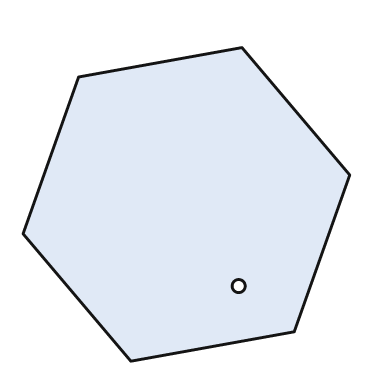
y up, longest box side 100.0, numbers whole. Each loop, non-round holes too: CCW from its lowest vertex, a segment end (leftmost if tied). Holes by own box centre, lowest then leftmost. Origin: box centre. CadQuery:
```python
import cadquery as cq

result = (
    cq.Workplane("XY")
    .moveTo(-17.0, -48.0)
    .lineTo(33.0, -39.0)
    .lineTo(50.0, 9.0)
    .lineTo(17.0, 48.0)
    .lineTo(-33.0, 39.0)
    .lineTo(-50.0, -9.0)
    .close()
    .moveTo(16.0, -25.0)
    .circle(2.0)
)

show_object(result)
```